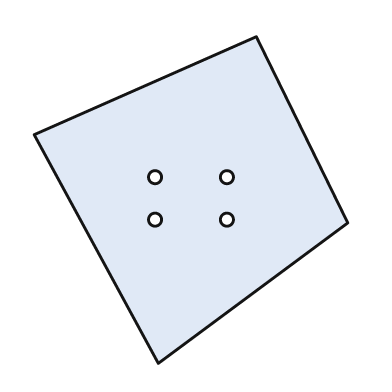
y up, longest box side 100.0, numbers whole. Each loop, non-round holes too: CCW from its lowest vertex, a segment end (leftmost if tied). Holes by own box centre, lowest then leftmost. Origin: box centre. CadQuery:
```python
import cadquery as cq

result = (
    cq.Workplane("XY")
    .moveTo(-10.0, -50.0)
    .lineTo(48.0, -7.0)
    .lineTo(20.0, 50.0)
    .lineTo(-48.0, 20.0)
    .close()
    .moveTo(-11.0, -6.0)
    .circle(2.0)
    .moveTo(11.0, -6.0)
    .circle(2.0)
    .moveTo(-11.0, 7.0)
    .circle(2.0)
    .moveTo(11.0, 7.0)
    .circle(2.0)
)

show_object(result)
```